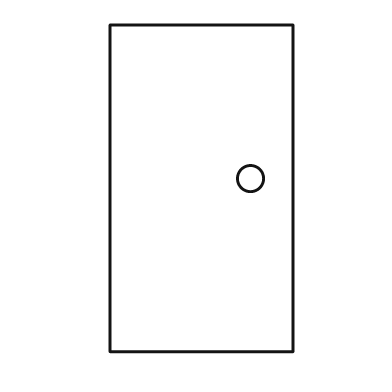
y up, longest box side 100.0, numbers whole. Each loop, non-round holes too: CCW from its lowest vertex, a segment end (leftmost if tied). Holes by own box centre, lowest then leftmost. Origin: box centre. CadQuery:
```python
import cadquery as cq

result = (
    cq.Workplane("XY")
    .moveTo(-28.0, -50.0)
    .lineTo(28.0, -50.0)
    .lineTo(28.0, 50.0)
    .lineTo(-28.0, 50.0)
    .close()
    .moveTo(15.0, 3.0)
    .circle(4.0)
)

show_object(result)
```